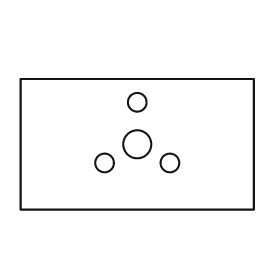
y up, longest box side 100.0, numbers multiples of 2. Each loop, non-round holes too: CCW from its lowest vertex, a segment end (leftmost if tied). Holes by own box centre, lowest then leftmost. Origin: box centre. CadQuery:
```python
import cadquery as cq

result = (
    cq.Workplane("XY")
    .moveTo(-50.0, -28.0)
    .lineTo(50.0, -28.0)
    .lineTo(50.0, 28.0)
    .lineTo(-50.0, 28.0)
    .close()
    .moveTo(-14.0, -8.0)
    .circle(4.0)
    .moveTo(14.0, -8.0)
    .circle(4.0)
    .moveTo(0.0, 0.0)
    .circle(6.0)
    .moveTo(0.0, 18.0)
    .circle(4.0)
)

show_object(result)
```